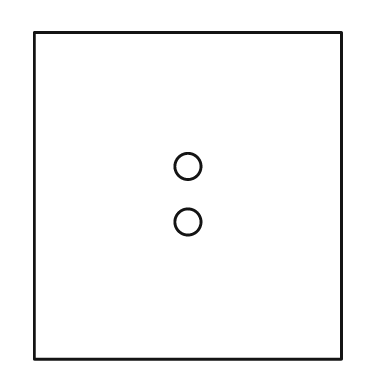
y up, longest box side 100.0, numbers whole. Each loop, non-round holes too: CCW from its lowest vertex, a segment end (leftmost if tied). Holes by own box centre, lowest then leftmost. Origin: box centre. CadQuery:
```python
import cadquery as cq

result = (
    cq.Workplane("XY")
    .moveTo(-47.0, -50.0)
    .lineTo(47.0, -50.0)
    .lineTo(47.0, 50.0)
    .lineTo(-47.0, 50.0)
    .close()
    .moveTo(0.0, -8.0)
    .circle(4.0)
    .moveTo(0.0, 9.0)
    .circle(4.0)
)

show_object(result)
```